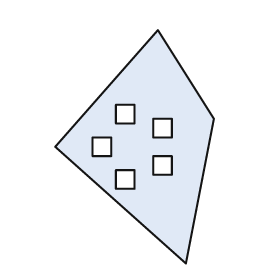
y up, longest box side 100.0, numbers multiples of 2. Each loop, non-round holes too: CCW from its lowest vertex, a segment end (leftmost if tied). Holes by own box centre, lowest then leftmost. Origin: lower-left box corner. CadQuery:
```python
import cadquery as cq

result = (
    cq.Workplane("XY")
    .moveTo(56.0, 0.0)
    .lineTo(68.0, 62.0)
    .lineTo(44.0, 100.0)
    .lineTo(0.0, 50.0)
    .close()
    .moveTo(26.0, 32.0)
    .lineTo(34.0, 32.0)
    .lineTo(34.0, 40.0)
    .lineTo(26.0, 40.0)
    .close()
    .moveTo(42.0, 38.0)
    .lineTo(50.0, 38.0)
    .lineTo(50.0, 46.0)
    .lineTo(42.0, 46.0)
    .close()
    .moveTo(16.0, 46.0)
    .lineTo(24.0, 46.0)
    .lineTo(24.0, 54.0)
    .lineTo(16.0, 54.0)
    .close()
    .moveTo(42.0, 54.0)
    .lineTo(50.0, 54.0)
    .lineTo(50.0, 62.0)
    .lineTo(42.0, 62.0)
    .close()
    .moveTo(26.0, 60.0)
    .lineTo(34.0, 60.0)
    .lineTo(34.0, 68.0)
    .lineTo(26.0, 68.0)
    .close()
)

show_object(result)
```